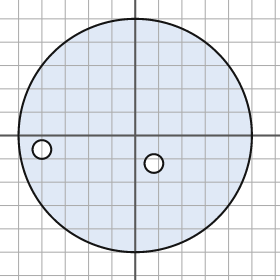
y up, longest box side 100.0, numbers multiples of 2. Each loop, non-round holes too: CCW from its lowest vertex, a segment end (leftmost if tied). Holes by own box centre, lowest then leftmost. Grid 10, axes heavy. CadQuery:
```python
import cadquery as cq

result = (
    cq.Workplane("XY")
    .moveTo(0.0, 0.0)
    .circle(50.0)
    .moveTo(8.0, -12.0)
    .circle(4.0)
    .moveTo(-40.0, -6.0)
    .circle(4.0)
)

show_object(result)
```